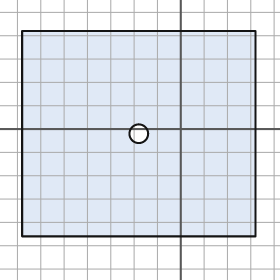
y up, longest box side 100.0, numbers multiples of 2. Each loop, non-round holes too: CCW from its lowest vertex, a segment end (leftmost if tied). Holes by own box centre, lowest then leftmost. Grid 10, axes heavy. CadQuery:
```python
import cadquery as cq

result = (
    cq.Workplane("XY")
    .moveTo(-68.0, -46.0)
    .lineTo(32.0, -46.0)
    .lineTo(32.0, 42.0)
    .lineTo(-68.0, 42.0)
    .close()
    .moveTo(-18.0, -2.0)
    .circle(4.0)
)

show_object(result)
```